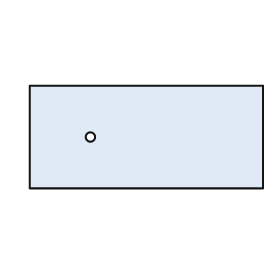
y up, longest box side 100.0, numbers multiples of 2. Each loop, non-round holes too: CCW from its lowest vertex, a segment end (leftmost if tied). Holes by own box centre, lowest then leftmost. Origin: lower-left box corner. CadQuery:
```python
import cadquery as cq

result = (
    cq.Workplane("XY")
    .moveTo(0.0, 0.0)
    .lineTo(100.0, 0.0)
    .lineTo(100.0, 44.0)
    .lineTo(0.0, 44.0)
    .close()
    .moveTo(26.0, 22.0)
    .circle(2.0)
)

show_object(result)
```